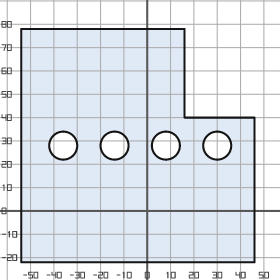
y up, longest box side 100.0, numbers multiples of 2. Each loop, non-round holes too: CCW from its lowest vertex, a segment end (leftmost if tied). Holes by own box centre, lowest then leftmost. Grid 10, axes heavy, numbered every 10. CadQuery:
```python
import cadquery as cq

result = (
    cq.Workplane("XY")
    .moveTo(-54.0, -22.0)
    .lineTo(46.0, -22.0)
    .lineTo(46.0, 40.0)
    .lineTo(16.0, 40.0)
    .lineTo(16.0, 78.0)
    .lineTo(-54.0, 78.0)
    .close()
    .moveTo(-36.0, 28.0)
    .circle(6.0)
    .moveTo(-14.0, 28.0)
    .circle(6.0)
    .moveTo(8.0, 28.0)
    .circle(6.0)
    .moveTo(30.0, 28.0)
    .circle(6.0)
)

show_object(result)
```